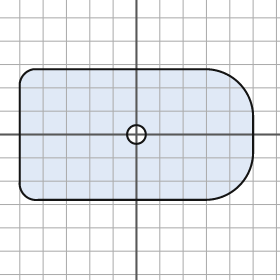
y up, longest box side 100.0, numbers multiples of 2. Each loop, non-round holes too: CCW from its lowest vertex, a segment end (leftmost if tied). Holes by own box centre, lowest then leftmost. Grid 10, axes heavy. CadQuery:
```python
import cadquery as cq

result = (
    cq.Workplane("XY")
    .moveTo(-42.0, -28.0)
    .lineTo(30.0, -28.0)
    .threePointArc((44.0, -22.0), (50.0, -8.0))
    .lineTo(50.0, 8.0)
    .threePointArc((44.0, 22.0), (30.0, 28.0))
    .lineTo(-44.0, 28.0)
    .threePointArc((-48.0, 26.0), (-50.0, 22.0))
    .lineTo(-50.0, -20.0)
    .threePointArc((-48.0, -26.0), (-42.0, -28.0))
    .close()
    .moveTo(0.0, 0.0)
    .circle(4.0)
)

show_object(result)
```